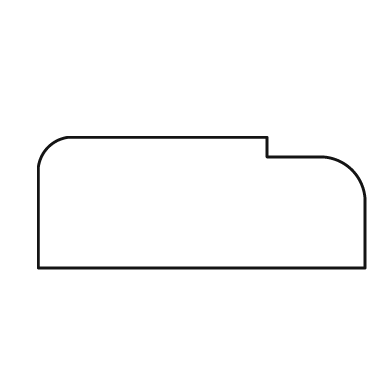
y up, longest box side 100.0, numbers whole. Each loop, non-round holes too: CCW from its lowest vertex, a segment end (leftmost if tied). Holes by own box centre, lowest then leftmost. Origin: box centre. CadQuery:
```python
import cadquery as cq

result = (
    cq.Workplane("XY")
    .moveTo(-50.0, -20.0)
    .lineTo(50.0, -20.0)
    .lineTo(50.0, 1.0)
    .threePointArc((46.0, 10.0), (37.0, 14.0))
    .lineTo(20.0, 14.0)
    .lineTo(20.0, 20.0)
    .lineTo(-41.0, 20.0)
    .threePointArc((-47.0, 17.0), (-50.0, 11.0))
    .close()
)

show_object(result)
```